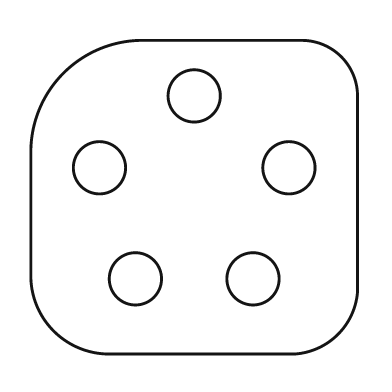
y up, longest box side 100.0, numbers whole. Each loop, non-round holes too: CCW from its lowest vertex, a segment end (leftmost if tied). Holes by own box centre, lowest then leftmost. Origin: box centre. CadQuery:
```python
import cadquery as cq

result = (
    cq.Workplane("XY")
    .moveTo(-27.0, -48.0)
    .lineTo(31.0, -48.0)
    .threePointArc((44.0, -42.0), (50.0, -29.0))
    .lineTo(50.0, 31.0)
    .threePointArc((45.0, 43.0), (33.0, 48.0))
    .lineTo(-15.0, 48.0)
    .threePointArc((-40.0, 38.0), (-50.0, 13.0))
    .lineTo(-50.0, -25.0)
    .threePointArc((-43.0, -41.0), (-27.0, -48.0))
    .close()
    .moveTo(-18.0, -25.0)
    .circle(8.0)
    .moveTo(18.0, -25.0)
    .circle(8.0)
    .moveTo(-29.0, 9.0)
    .circle(8.0)
    .moveTo(29.0, 9.0)
    .circle(8.0)
    .moveTo(0.0, 31.0)
    .circle(8.0)
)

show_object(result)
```